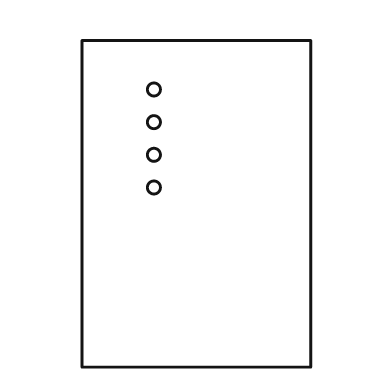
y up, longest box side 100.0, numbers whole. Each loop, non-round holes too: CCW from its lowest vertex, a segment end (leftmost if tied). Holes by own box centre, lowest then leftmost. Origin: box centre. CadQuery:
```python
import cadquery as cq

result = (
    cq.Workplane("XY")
    .moveTo(-35.0, -50.0)
    .lineTo(35.0, -50.0)
    .lineTo(35.0, 50.0)
    .lineTo(-35.0, 50.0)
    .close()
    .moveTo(-13.0, 5.0)
    .circle(2.0)
    .moveTo(-13.0, 15.0)
    .circle(2.0)
    .moveTo(-13.0, 25.0)
    .circle(2.0)
    .moveTo(-13.0, 35.0)
    .circle(2.0)
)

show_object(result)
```